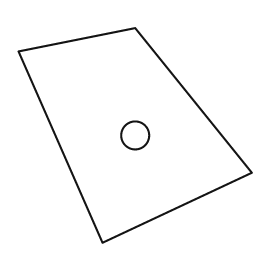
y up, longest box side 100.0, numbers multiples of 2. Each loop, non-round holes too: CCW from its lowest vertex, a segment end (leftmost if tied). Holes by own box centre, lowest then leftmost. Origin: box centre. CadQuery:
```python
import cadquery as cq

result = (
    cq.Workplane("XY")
    .moveTo(-14.0, -46.0)
    .lineTo(50.0, -16.0)
    .lineTo(0.0, 46.0)
    .lineTo(-50.0, 36.0)
    .close()
    .moveTo(0.0, 0.0)
    .circle(6.0)
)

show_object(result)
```